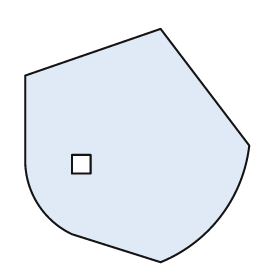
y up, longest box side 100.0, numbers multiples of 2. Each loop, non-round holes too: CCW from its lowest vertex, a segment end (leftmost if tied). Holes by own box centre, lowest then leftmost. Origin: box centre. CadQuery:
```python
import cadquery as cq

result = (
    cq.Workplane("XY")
    .moveTo(10.0, -50.0)
    .threePointArc((36.0, -30.0), (48.0, 0.0))
    .lineTo(10.0, 50.0)
    .lineTo(-48.0, 30.0)
    .lineTo(-48.0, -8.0)
    .threePointArc((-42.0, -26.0), (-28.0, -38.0))
    .close()
    .moveTo(-28.0, -12.0)
    .lineTo(-20.0, -12.0)
    .lineTo(-20.0, -4.0)
    .lineTo(-28.0, -4.0)
    .close()
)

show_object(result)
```